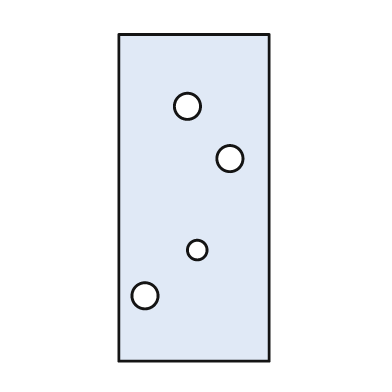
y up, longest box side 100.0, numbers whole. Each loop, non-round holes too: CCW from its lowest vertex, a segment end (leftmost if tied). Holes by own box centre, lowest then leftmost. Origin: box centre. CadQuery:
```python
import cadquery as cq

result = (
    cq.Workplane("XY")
    .moveTo(-23.0, -50.0)
    .lineTo(23.0, -50.0)
    .lineTo(23.0, 50.0)
    .lineTo(-23.0, 50.0)
    .close()
    .moveTo(-15.0, -30.0)
    .circle(4.0)
    .moveTo(1.0, -16.0)
    .circle(3.0)
    .moveTo(11.0, 12.0)
    .circle(4.0)
    .moveTo(-2.0, 28.0)
    .circle(4.0)
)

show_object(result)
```